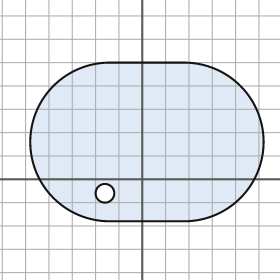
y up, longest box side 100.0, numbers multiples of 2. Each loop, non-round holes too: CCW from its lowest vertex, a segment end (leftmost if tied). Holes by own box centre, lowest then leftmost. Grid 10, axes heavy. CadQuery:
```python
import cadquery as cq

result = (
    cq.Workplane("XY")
    .moveTo(-14.0, -18.0)
    .lineTo(18.0, -18.0)
    .threePointArc((52.0, 16.0), (18.0, 50.0))
    .lineTo(-14.0, 50.0)
    .threePointArc((-48.0, 16.0), (-14.0, -18.0))
    .close()
    .moveTo(-16.0, -6.0)
    .circle(4.0)
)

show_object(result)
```